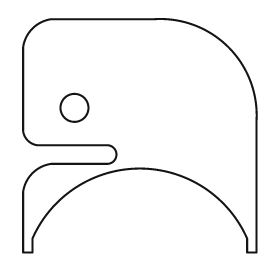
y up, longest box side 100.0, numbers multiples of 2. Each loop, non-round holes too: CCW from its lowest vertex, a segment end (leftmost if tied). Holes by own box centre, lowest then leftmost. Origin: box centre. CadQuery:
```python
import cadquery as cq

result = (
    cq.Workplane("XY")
    .moveTo(-50.0, -50.0)
    .lineTo(-46.0, -50.0)
    .lineTo(-46.0, -44.0)
    .threePointArc((0.0, -14.0), (46.0, -44.0))
    .lineTo(46.0, -50.0)
    .lineTo(50.0, -50.0)
    .lineTo(50.0, 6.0)
    .threePointArc((38.0, 38.0), (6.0, 50.0))
    .lineTo(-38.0, 50.0)
    .threePointArc((-46.0, 46.0), (-50.0, 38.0))
    .lineTo(-50.0, 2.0)
    .threePointArc((-48.0, -2.0), (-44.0, -4.0))
    .lineTo(-14.0, -4.0)
    .threePointArc((-10.0, -8.0), (-14.0, -12.0))
    .lineTo(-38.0, -12.0)
    .threePointArc((-46.0, -16.0), (-50.0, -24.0))
    .close()
    .moveTo(-28.0, 12.0)
    .circle(6.0)
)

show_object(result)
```